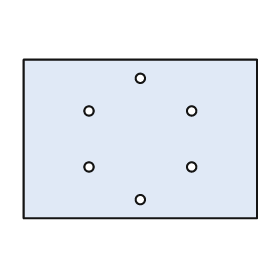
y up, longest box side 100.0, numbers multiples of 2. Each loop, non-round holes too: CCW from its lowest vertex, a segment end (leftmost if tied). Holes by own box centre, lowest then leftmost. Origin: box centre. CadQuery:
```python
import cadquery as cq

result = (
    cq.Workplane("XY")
    .moveTo(-50.0, -34.0)
    .lineTo(50.0, -34.0)
    .lineTo(50.0, 34.0)
    .lineTo(-50.0, 34.0)
    .close()
    .moveTo(0.0, -26.0)
    .circle(2.0)
    .moveTo(-22.0, -12.0)
    .circle(2.0)
    .moveTo(22.0, -12.0)
    .circle(2.0)
    .moveTo(-22.0, 12.0)
    .circle(2.0)
    .moveTo(22.0, 12.0)
    .circle(2.0)
    .moveTo(0.0, 26.0)
    .circle(2.0)
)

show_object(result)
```